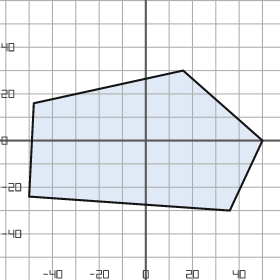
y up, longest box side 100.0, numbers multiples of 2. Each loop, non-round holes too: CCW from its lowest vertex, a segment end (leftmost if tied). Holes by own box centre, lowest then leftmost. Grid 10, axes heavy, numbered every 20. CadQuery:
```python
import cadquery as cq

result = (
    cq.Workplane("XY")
    .moveTo(36.0, -30.0)
    .lineTo(50.0, 0.0)
    .lineTo(16.0, 30.0)
    .lineTo(-48.0, 16.0)
    .lineTo(-50.0, -24.0)
    .close()
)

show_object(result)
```